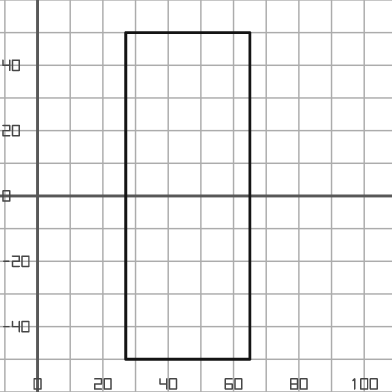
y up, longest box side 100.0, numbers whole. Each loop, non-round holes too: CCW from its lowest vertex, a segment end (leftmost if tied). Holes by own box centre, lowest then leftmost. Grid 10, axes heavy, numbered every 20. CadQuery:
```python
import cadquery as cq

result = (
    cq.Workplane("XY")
    .moveTo(27.0, -50.0)
    .lineTo(65.0, -50.0)
    .lineTo(65.0, 50.0)
    .lineTo(27.0, 50.0)
    .close()
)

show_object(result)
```